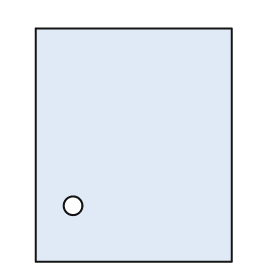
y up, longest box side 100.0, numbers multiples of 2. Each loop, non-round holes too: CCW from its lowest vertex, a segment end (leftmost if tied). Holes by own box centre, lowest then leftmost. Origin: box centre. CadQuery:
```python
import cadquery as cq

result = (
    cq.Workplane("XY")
    .moveTo(-42.0, -50.0)
    .lineTo(42.0, -50.0)
    .lineTo(42.0, 50.0)
    .lineTo(-42.0, 50.0)
    .close()
    .moveTo(-26.0, -26.0)
    .circle(4.0)
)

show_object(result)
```